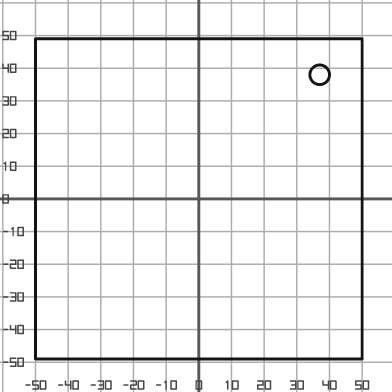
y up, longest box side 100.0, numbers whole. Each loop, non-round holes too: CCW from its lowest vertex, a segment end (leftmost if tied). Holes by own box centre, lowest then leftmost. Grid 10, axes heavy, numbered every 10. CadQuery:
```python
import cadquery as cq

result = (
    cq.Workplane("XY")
    .moveTo(-50.0, -49.0)
    .lineTo(50.0, -49.0)
    .lineTo(50.0, 49.0)
    .lineTo(-50.0, 49.0)
    .close()
    .moveTo(37.0, 38.0)
    .circle(3.0)
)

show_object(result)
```